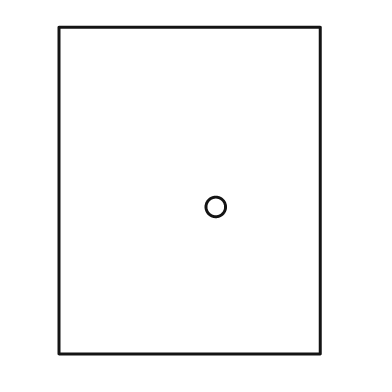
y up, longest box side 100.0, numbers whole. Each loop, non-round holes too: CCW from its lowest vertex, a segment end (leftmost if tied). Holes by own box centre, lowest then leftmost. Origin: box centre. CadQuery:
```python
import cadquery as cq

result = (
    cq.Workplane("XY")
    .moveTo(-40.0, -50.0)
    .lineTo(40.0, -50.0)
    .lineTo(40.0, 50.0)
    .lineTo(-40.0, 50.0)
    .close()
    .moveTo(8.0, -5.0)
    .circle(3.0)
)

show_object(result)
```